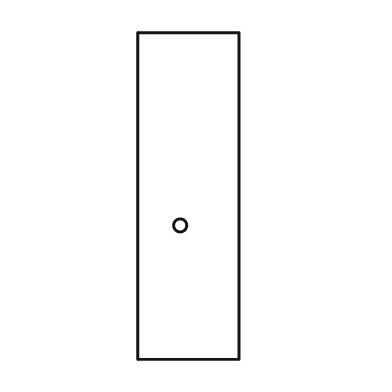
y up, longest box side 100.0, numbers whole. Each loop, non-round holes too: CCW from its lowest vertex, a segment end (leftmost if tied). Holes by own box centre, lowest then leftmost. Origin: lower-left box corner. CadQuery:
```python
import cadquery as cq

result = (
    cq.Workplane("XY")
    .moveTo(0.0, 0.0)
    .lineTo(31.0, 0.0)
    .lineTo(31.0, 100.0)
    .lineTo(0.0, 100.0)
    .close()
    .moveTo(13.0, 41.0)
    .circle(2.0)
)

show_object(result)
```